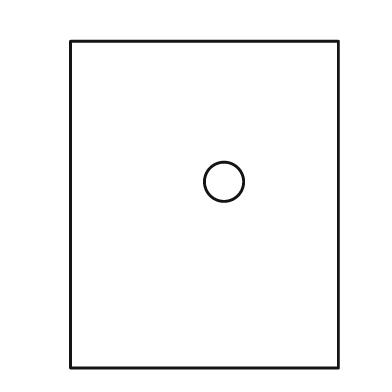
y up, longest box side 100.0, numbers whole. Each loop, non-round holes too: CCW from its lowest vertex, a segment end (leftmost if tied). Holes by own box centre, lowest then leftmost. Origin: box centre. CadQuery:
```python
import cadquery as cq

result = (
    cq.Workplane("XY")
    .moveTo(-41.0, -50.0)
    .lineTo(41.0, -50.0)
    .lineTo(41.0, 50.0)
    .lineTo(-41.0, 50.0)
    .close()
    .moveTo(6.0, 7.0)
    .circle(6.0)
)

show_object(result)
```